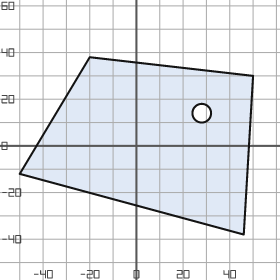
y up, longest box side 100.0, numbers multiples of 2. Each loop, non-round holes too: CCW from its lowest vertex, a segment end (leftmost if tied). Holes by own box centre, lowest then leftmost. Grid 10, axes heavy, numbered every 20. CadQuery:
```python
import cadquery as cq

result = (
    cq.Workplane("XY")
    .moveTo(46.0, -38.0)
    .lineTo(50.0, 30.0)
    .lineTo(-20.0, 38.0)
    .lineTo(-50.0, -12.0)
    .close()
    .moveTo(28.0, 14.0)
    .circle(4.0)
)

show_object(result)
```